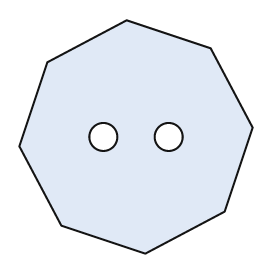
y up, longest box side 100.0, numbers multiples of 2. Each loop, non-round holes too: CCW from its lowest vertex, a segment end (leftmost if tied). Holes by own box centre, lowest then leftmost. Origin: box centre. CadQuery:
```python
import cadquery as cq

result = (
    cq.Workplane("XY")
    .moveTo(4.0, -50.0)
    .lineTo(38.0, -32.0)
    .lineTo(50.0, 4.0)
    .lineTo(32.0, 38.0)
    .lineTo(-4.0, 50.0)
    .lineTo(-38.0, 32.0)
    .lineTo(-50.0, -4.0)
    .lineTo(-32.0, -38.0)
    .close()
    .moveTo(-14.0, 0.0)
    .circle(6.0)
    .moveTo(14.0, 0.0)
    .circle(6.0)
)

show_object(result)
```